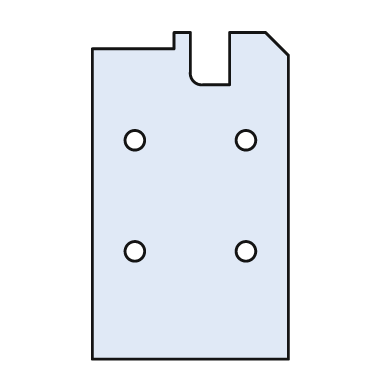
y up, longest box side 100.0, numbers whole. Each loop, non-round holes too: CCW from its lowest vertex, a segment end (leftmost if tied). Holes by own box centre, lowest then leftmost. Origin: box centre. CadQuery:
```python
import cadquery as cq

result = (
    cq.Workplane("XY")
    .moveTo(-30.0, -50.0)
    .lineTo(30.0, -50.0)
    .lineTo(30.0, 43.0)
    .lineTo(23.0, 50.0)
    .lineTo(12.0, 50.0)
    .lineTo(12.0, 34.0)
    .lineTo(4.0, 34.0)
    .threePointArc((1.0, 35.0), (0.0, 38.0))
    .lineTo(0.0, 50.0)
    .lineTo(-5.0, 50.0)
    .lineTo(-5.0, 45.0)
    .lineTo(-30.0, 45.0)
    .close()
    .moveTo(-17.0, -17.0)
    .circle(3.0)
    .moveTo(17.0, -17.0)
    .circle(3.0)
    .moveTo(-17.0, 17.0)
    .circle(3.0)
    .moveTo(17.0, 17.0)
    .circle(3.0)
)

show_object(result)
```